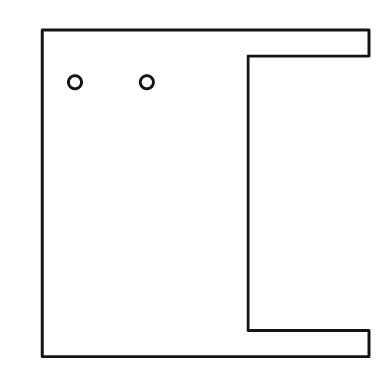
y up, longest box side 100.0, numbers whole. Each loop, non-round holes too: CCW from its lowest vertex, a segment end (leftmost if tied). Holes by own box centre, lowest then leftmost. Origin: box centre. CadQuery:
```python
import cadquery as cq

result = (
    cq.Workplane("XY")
    .moveTo(-50.0, -50.0)
    .lineTo(50.0, -50.0)
    .lineTo(50.0, -42.0)
    .lineTo(13.0, -42.0)
    .lineTo(13.0, 42.0)
    .lineTo(50.0, 42.0)
    .lineTo(50.0, 50.0)
    .lineTo(-50.0, 50.0)
    .close()
    .moveTo(-40.0, 34.0)
    .circle(2.0)
    .moveTo(-18.0, 34.0)
    .circle(2.0)
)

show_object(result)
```